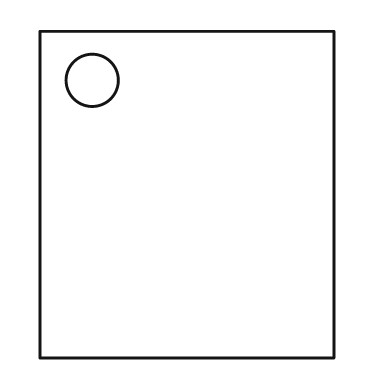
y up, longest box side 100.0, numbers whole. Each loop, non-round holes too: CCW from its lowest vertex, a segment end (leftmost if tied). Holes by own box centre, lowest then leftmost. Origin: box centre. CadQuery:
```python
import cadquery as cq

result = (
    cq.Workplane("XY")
    .moveTo(-45.0, -50.0)
    .lineTo(45.0, -50.0)
    .lineTo(45.0, 50.0)
    .lineTo(-45.0, 50.0)
    .close()
    .moveTo(-29.0, 35.0)
    .circle(8.0)
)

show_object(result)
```